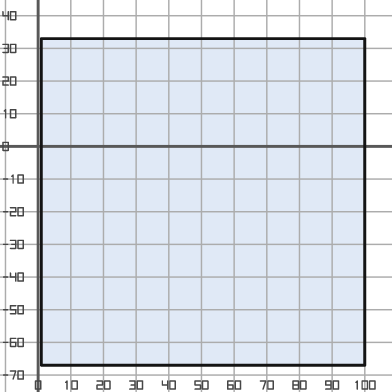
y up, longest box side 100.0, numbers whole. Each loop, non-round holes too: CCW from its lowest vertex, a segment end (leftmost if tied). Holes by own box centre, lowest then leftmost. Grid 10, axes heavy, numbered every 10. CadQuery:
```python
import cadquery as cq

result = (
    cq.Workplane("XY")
    .moveTo(1.0, -67.0)
    .lineTo(100.0, -67.0)
    .lineTo(100.0, 33.0)
    .lineTo(1.0, 33.0)
    .close()
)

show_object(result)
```